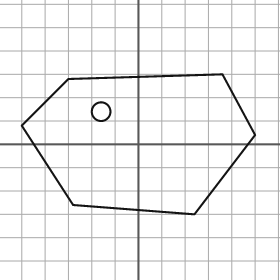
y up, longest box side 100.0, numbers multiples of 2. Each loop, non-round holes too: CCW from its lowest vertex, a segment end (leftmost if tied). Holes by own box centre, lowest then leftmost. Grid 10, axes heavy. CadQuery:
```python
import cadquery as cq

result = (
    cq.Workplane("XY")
    .moveTo(24.0, -30.0)
    .lineTo(50.0, 4.0)
    .lineTo(36.0, 30.0)
    .lineTo(-30.0, 28.0)
    .lineTo(-50.0, 8.0)
    .lineTo(-28.0, -26.0)
    .close()
    .moveTo(-16.0, 14.0)
    .circle(4.0)
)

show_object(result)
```